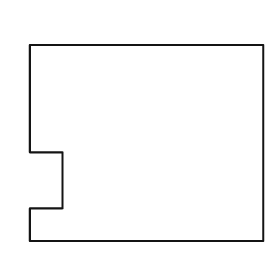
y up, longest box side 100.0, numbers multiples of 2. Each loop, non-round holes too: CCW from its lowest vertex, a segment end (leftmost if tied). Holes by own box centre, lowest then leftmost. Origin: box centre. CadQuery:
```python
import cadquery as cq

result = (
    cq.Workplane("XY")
    .moveTo(-50.0, -42.0)
    .lineTo(50.0, -42.0)
    .lineTo(50.0, 42.0)
    .lineTo(-50.0, 42.0)
    .lineTo(-50.0, -4.0)
    .lineTo(-36.0, -4.0)
    .lineTo(-36.0, -28.0)
    .lineTo(-50.0, -28.0)
    .close()
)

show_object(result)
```